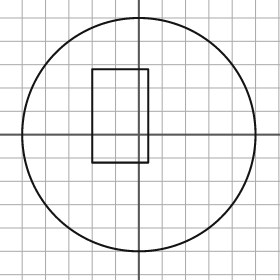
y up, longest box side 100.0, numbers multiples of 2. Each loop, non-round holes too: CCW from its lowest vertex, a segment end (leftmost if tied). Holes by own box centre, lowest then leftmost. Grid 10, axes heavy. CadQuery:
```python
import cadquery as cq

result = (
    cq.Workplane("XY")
    .moveTo(0.0, 0.0)
    .circle(50.0)
    .moveTo(-20.0, -12.0)
    .lineTo(4.0, -12.0)
    .lineTo(4.0, 28.0)
    .lineTo(-20.0, 28.0)
    .close()
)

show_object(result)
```